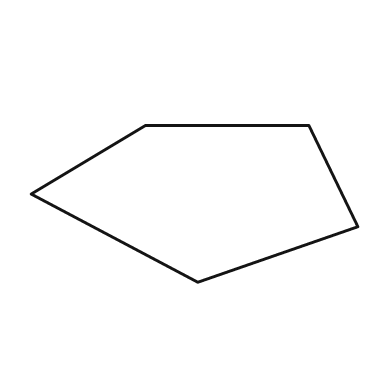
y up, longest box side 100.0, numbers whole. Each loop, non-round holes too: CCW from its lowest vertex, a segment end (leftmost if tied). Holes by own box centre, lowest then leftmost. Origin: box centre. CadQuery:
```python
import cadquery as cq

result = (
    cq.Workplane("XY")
    .moveTo(1.0, -24.0)
    .lineTo(50.0, -7.0)
    .lineTo(35.0, 24.0)
    .lineTo(-15.0, 24.0)
    .lineTo(-50.0, 3.0)
    .close()
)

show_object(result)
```